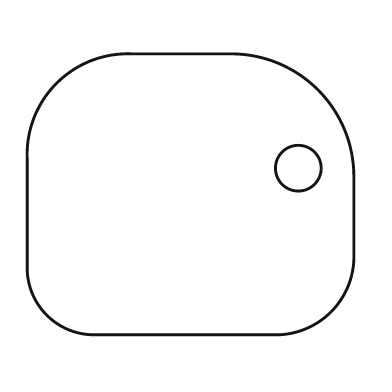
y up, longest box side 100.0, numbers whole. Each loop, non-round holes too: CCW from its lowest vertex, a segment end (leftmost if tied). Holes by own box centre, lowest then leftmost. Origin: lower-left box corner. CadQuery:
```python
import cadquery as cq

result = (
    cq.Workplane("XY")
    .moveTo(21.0, 0.0)
    .lineTo(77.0, 0.0)
    .threePointArc((93.0, 7.0), (100.0, 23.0))
    .lineTo(100.0, 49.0)
    .threePointArc((89.0, 75.0), (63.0, 86.0))
    .lineTo(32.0, 86.0)
    .threePointArc((9.0, 77.0), (0.0, 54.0))
    .lineTo(0.0, 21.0)
    .threePointArc((6.0, 6.0), (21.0, 0.0))
    .close()
    .moveTo(83.0, 51.0)
    .circle(7.0)
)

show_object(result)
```